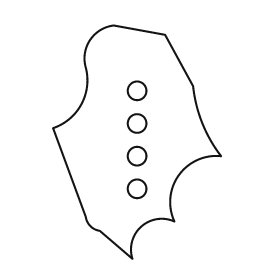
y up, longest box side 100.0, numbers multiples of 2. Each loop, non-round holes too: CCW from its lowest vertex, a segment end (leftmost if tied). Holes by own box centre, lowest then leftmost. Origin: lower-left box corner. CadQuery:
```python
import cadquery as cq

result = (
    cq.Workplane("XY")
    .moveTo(34.0, 0.0)
    .threePointArc((38.0, 14.0), (52.0, 16.0))
    .threePointArc((54.0, 36.0), (72.0, 44.0))
    .threePointArc((64.0, 58.0), (60.0, 74.0))
    .lineTo(48.0, 96.0)
    .lineTo(26.0, 100.0)
    .threePointArc((16.0, 94.0), (14.0, 82.0))
    .threePointArc((12.0, 66.0), (0.0, 56.0))
    .lineTo(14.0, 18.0)
    .threePointArc((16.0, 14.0), (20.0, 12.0))
    .close()
    .moveTo(36.0, 30.0)
    .circle(4.0)
    .moveTo(36.0, 44.0)
    .circle(4.0)
    .moveTo(36.0, 58.0)
    .circle(4.0)
    .moveTo(36.0, 72.0)
    .circle(4.0)
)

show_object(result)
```